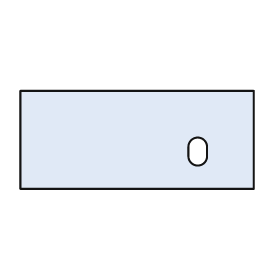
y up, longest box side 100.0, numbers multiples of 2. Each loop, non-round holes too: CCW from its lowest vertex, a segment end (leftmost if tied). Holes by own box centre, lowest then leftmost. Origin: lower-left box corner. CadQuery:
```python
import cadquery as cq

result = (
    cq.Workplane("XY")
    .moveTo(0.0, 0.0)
    .lineTo(100.0, 0.0)
    .lineTo(100.0, 42.0)
    .lineTo(0.0, 42.0)
    .close()
    .moveTo(72.0, 14.0)
    .threePointArc((76.0, 10.0), (80.0, 14.0))
    .lineTo(80.0, 18.0)
    .threePointArc((76.0, 22.0), (72.0, 18.0))
    .close()
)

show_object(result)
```